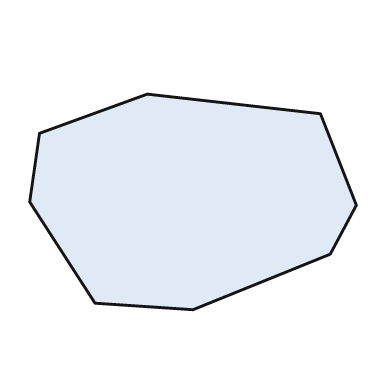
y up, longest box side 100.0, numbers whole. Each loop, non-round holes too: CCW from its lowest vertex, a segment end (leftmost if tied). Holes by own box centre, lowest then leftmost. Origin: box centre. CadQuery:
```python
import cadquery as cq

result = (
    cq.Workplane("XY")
    .moveTo(0.0, -33.0)
    .lineTo(42.0, -16.0)
    .lineTo(50.0, -1.0)
    .lineTo(39.0, 27.0)
    .lineTo(-14.0, 33.0)
    .lineTo(-47.0, 21.0)
    .lineTo(-50.0, 0.0)
    .lineTo(-30.0, -31.0)
    .close()
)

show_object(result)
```